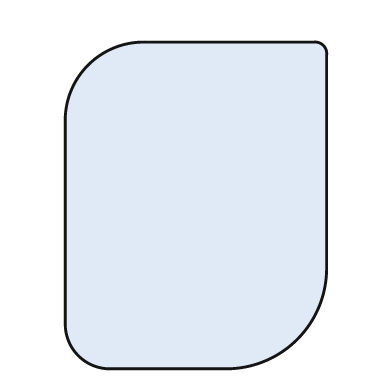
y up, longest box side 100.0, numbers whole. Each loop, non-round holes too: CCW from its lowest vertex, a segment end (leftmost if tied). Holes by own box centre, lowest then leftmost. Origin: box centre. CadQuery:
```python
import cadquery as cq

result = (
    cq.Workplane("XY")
    .moveTo(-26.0, -50.0)
    .lineTo(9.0, -50.0)
    .threePointArc((31.0, -41.0), (40.0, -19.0))
    .lineTo(40.0, 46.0)
    .threePointArc((39.0, 49.0), (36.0, 50.0))
    .lineTo(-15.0, 50.0)
    .threePointArc((-33.0, 43.0), (-40.0, 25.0))
    .lineTo(-40.0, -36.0)
    .threePointArc((-36.0, -46.0), (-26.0, -50.0))
    .close()
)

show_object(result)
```